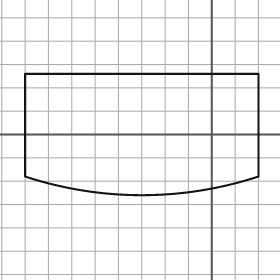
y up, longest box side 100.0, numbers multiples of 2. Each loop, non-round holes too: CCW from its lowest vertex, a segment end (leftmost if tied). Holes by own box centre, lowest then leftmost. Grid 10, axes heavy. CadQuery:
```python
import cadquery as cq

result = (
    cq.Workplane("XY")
    .moveTo(-80.0, -18.0)
    .threePointArc((-30.0, -26.0), (20.0, -18.0))
    .lineTo(20.0, 26.0)
    .lineTo(-80.0, 26.0)
    .close()
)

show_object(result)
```